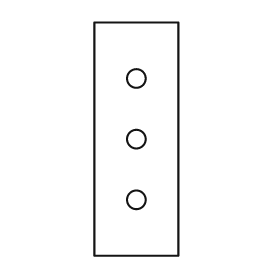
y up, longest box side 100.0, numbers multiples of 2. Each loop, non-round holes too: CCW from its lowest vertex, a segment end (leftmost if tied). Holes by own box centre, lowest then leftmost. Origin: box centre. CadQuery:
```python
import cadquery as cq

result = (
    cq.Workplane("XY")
    .moveTo(-18.0, -50.0)
    .lineTo(18.0, -50.0)
    .lineTo(18.0, 50.0)
    .lineTo(-18.0, 50.0)
    .close()
    .moveTo(0.0, -26.0)
    .circle(4.0)
    .moveTo(0.0, 0.0)
    .circle(4.0)
    .moveTo(0.0, 26.0)
    .circle(4.0)
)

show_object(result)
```